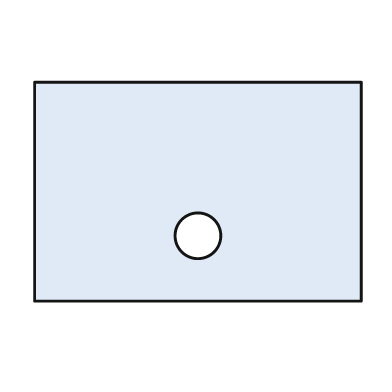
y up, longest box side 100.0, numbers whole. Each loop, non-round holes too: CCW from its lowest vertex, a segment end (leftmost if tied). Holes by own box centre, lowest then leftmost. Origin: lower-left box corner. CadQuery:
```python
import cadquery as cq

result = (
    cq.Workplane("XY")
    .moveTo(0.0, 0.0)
    .lineTo(100.0, 0.0)
    .lineTo(100.0, 67.0)
    .lineTo(0.0, 67.0)
    .close()
    .moveTo(50.0, 20.0)
    .circle(7.0)
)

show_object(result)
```